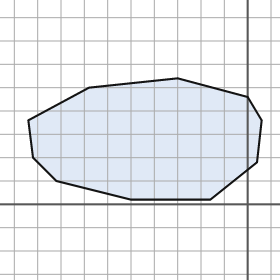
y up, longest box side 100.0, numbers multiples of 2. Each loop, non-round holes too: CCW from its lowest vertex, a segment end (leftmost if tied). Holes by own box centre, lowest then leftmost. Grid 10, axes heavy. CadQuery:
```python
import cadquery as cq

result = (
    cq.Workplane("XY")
    .moveTo(-50.0, 2.0)
    .lineTo(-16.0, 2.0)
    .lineTo(4.0, 18.0)
    .lineTo(6.0, 36.0)
    .lineTo(0.0, 46.0)
    .lineTo(-30.0, 54.0)
    .lineTo(-68.0, 50.0)
    .lineTo(-94.0, 36.0)
    .lineTo(-92.0, 20.0)
    .lineTo(-82.0, 10.0)
    .close()
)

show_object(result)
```